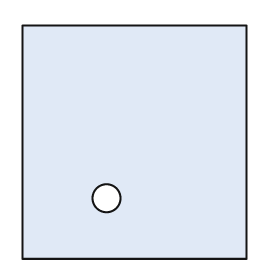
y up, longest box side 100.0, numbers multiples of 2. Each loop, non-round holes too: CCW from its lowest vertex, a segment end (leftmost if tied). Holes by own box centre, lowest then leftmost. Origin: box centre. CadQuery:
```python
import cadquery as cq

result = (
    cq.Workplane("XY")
    .moveTo(-48.0, -50.0)
    .lineTo(48.0, -50.0)
    .lineTo(48.0, 50.0)
    .lineTo(-48.0, 50.0)
    .close()
    .moveTo(-12.0, -24.0)
    .circle(6.0)
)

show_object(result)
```